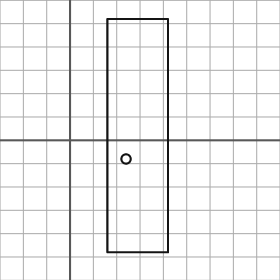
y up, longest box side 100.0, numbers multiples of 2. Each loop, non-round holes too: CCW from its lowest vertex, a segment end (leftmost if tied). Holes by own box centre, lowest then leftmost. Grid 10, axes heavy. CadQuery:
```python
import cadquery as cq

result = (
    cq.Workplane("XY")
    .moveTo(16.0, -48.0)
    .lineTo(42.0, -48.0)
    .lineTo(42.0, 52.0)
    .lineTo(16.0, 52.0)
    .close()
    .moveTo(24.0, -8.0)
    .circle(2.0)
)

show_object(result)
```